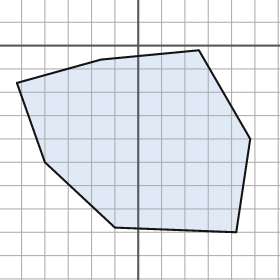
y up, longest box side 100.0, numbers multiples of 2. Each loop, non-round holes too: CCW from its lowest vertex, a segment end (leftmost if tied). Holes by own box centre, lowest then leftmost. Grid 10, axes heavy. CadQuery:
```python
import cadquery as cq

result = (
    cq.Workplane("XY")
    .moveTo(42.0, -80.0)
    .lineTo(48.0, -40.0)
    .lineTo(26.0, -2.0)
    .lineTo(-16.0, -6.0)
    .lineTo(-52.0, -16.0)
    .lineTo(-40.0, -50.0)
    .lineTo(-10.0, -78.0)
    .close()
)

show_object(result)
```